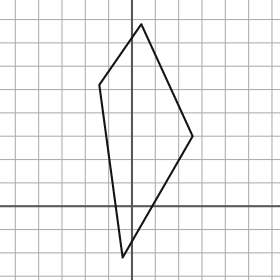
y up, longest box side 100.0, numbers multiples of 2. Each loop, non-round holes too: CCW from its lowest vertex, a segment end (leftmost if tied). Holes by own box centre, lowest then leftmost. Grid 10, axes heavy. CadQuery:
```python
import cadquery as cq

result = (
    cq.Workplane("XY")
    .moveTo(-4.0, -22.0)
    .lineTo(26.0, 30.0)
    .lineTo(4.0, 78.0)
    .lineTo(-14.0, 52.0)
    .close()
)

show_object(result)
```